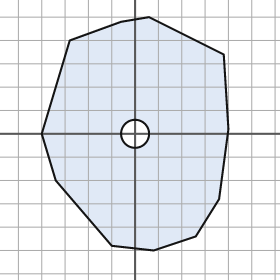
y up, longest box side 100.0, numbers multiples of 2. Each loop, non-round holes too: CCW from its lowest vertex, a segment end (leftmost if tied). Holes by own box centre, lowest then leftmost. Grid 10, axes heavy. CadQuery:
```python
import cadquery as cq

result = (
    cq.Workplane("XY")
    .moveTo(8.0, -50.0)
    .lineTo(26.0, -44.0)
    .lineTo(36.0, -28.0)
    .lineTo(40.0, 2.0)
    .lineTo(38.0, 34.0)
    .lineTo(6.0, 50.0)
    .lineTo(-6.0, 48.0)
    .lineTo(-28.0, 40.0)
    .lineTo(-40.0, 0.0)
    .lineTo(-34.0, -20.0)
    .lineTo(-10.0, -48.0)
    .close()
    .moveTo(0.0, 0.0)
    .circle(6.0)
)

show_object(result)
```